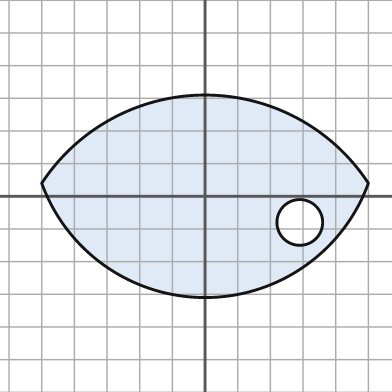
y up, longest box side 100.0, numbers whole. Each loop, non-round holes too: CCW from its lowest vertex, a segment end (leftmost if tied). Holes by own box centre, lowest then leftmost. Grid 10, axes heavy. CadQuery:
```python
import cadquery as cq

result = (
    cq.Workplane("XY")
    .moveTo(-50.0, 4.0)
    .threePointArc((0.0, -31.0), (50.0, 4.0))
    .threePointArc((0.0, 31.0), (-50.0, 4.0))
    .close()
    .moveTo(29.0, -8.0)
    .circle(7.0)
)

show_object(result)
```